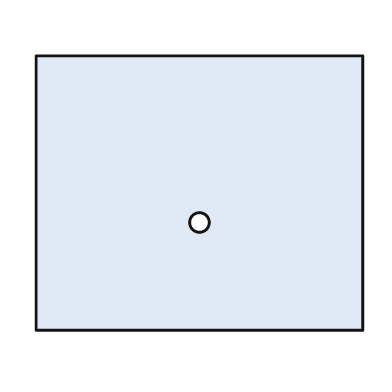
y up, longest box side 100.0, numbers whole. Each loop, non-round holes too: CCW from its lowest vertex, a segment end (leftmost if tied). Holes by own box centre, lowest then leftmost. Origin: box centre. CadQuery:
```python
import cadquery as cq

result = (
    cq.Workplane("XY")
    .moveTo(-50.0, -42.0)
    .lineTo(50.0, -42.0)
    .lineTo(50.0, 42.0)
    .lineTo(-50.0, 42.0)
    .close()
    .moveTo(0.0, -9.0)
    .circle(3.0)
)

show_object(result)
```